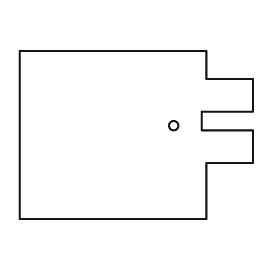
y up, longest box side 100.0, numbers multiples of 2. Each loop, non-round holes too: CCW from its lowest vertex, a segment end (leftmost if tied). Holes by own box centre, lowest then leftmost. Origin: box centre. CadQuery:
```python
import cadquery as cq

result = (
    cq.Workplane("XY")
    .moveTo(-50.0, -36.0)
    .lineTo(30.0, -36.0)
    .lineTo(30.0, -12.0)
    .lineTo(50.0, -12.0)
    .lineTo(50.0, 2.0)
    .lineTo(28.0, 2.0)
    .lineTo(28.0, 10.0)
    .lineTo(50.0, 10.0)
    .lineTo(50.0, 24.0)
    .lineTo(30.0, 24.0)
    .lineTo(30.0, 36.0)
    .lineTo(-50.0, 36.0)
    .close()
    .moveTo(16.0, 4.0)
    .circle(2.0)
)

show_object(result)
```